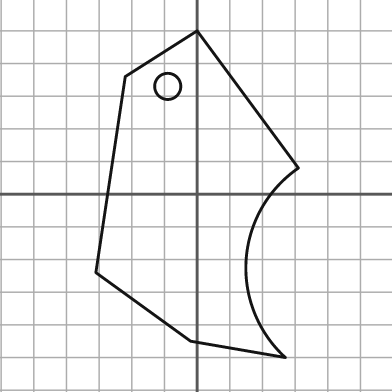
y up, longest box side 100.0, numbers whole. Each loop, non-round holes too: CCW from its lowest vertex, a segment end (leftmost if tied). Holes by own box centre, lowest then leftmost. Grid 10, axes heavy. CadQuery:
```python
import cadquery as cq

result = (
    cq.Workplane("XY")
    .moveTo(27.0, -50.0)
    .threePointArc((15.0, -20.0), (31.0, 8.0))
    .lineTo(0.0, 50.0)
    .lineTo(-22.0, 36.0)
    .lineTo(-31.0, -24.0)
    .lineTo(-2.0, -45.0)
    .close()
    .moveTo(-9.0, 33.0)
    .circle(4.0)
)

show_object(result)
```